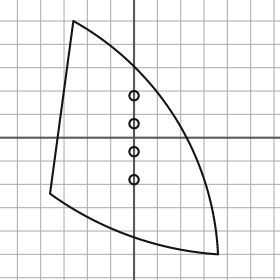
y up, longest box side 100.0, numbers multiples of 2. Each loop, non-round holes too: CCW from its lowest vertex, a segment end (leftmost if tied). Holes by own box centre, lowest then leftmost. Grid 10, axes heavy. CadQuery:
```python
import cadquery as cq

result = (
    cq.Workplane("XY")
    .moveTo(36.0, -50.0)
    .threePointArc((18.0, 8.0), (-26.0, 50.0))
    .lineTo(-36.0, -24.0)
    .threePointArc((-2.0, -42.0), (36.0, -50.0))
    .close()
    .moveTo(0.0, -18.0)
    .circle(2.0)
    .moveTo(0.0, -6.0)
    .circle(2.0)
    .moveTo(0.0, 6.0)
    .circle(2.0)
    .moveTo(0.0, 18.0)
    .circle(2.0)
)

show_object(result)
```